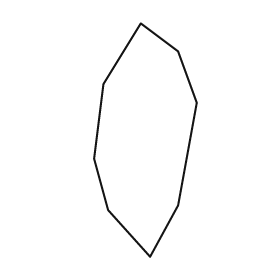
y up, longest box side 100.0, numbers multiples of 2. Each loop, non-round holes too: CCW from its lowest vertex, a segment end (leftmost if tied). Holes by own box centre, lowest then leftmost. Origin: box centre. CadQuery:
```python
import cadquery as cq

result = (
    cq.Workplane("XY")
    .moveTo(2.0, -50.0)
    .lineTo(14.0, -28.0)
    .lineTo(22.0, 16.0)
    .lineTo(14.0, 38.0)
    .lineTo(-2.0, 50.0)
    .lineTo(-18.0, 24.0)
    .lineTo(-22.0, -8.0)
    .lineTo(-16.0, -30.0)
    .close()
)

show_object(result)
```